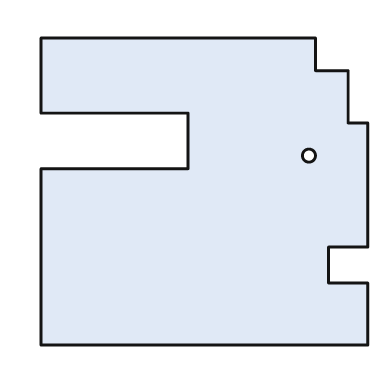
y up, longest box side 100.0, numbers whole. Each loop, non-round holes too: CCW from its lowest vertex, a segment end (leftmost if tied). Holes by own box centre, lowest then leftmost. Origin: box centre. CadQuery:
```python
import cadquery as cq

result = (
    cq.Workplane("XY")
    .moveTo(-50.0, -47.0)
    .lineTo(50.0, -47.0)
    .lineTo(50.0, -28.0)
    .lineTo(38.0, -28.0)
    .lineTo(38.0, -17.0)
    .lineTo(50.0, -17.0)
    .lineTo(50.0, 21.0)
    .lineTo(44.0, 21.0)
    .lineTo(44.0, 37.0)
    .lineTo(34.0, 37.0)
    .lineTo(34.0, 47.0)
    .lineTo(-50.0, 47.0)
    .lineTo(-50.0, 24.0)
    .lineTo(-5.0, 24.0)
    .lineTo(-5.0, 7.0)
    .lineTo(-50.0, 7.0)
    .close()
    .moveTo(32.0, 11.0)
    .circle(2.0)
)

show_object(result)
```